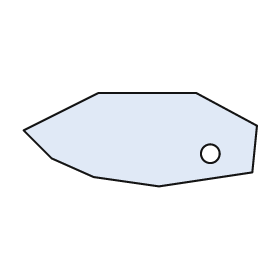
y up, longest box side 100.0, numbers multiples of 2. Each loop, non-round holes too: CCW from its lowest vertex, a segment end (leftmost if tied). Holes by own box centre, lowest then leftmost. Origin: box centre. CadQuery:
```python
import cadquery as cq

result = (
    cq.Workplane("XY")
    .moveTo(8.0, -20.0)
    .lineTo(48.0, -14.0)
    .lineTo(50.0, 6.0)
    .lineTo(24.0, 20.0)
    .lineTo(-18.0, 20.0)
    .lineTo(-50.0, 4.0)
    .lineTo(-38.0, -8.0)
    .lineTo(-20.0, -16.0)
    .close()
    .moveTo(30.0, -6.0)
    .circle(4.0)
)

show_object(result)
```